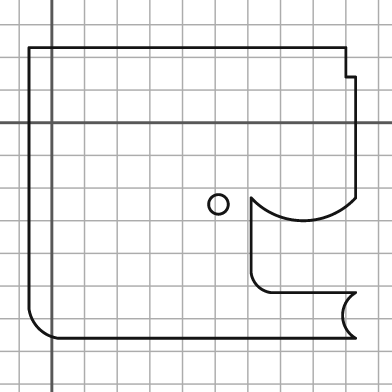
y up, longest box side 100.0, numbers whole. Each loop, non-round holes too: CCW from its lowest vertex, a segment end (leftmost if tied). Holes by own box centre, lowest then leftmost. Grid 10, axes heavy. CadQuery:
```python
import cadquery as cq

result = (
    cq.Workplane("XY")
    .moveTo(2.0, -66.0)
    .lineTo(93.0, -66.0)
    .threePointArc((89.0, -59.0), (93.0, -52.0))
    .lineTo(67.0, -52.0)
    .threePointArc((63.0, -50.0), (61.0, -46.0))
    .lineTo(61.0, -23.0)
    .threePointArc((77.0, -30.0), (93.0, -23.0))
    .lineTo(93.0, 14.0)
    .lineTo(90.0, 14.0)
    .lineTo(90.0, 23.0)
    .lineTo(-7.0, 23.0)
    .lineTo(-7.0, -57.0)
    .threePointArc((-4.0, -63.0), (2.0, -66.0))
    .close()
    .moveTo(51.0, -25.0)
    .circle(3.0)
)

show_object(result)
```